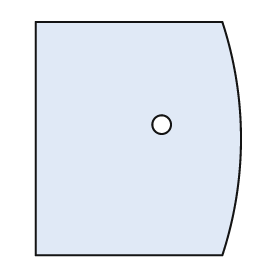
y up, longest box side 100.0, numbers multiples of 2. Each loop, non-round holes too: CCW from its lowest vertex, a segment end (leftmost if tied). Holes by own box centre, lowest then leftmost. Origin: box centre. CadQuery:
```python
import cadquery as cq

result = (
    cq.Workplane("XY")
    .moveTo(-44.0, -50.0)
    .lineTo(36.0, -50.0)
    .threePointArc((44.0, 0.0), (36.0, 50.0))
    .lineTo(-44.0, 50.0)
    .close()
    .moveTo(10.0, 6.0)
    .circle(4.0)
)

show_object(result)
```